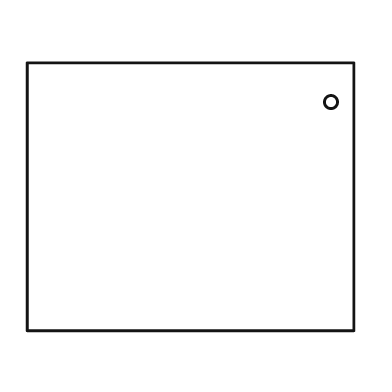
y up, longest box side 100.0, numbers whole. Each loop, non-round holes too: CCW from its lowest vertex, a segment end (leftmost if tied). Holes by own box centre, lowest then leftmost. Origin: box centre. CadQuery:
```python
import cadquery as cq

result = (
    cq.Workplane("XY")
    .moveTo(-50.0, -41.0)
    .lineTo(50.0, -41.0)
    .lineTo(50.0, 41.0)
    .lineTo(-50.0, 41.0)
    .close()
    .moveTo(43.0, 29.0)
    .circle(2.0)
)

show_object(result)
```